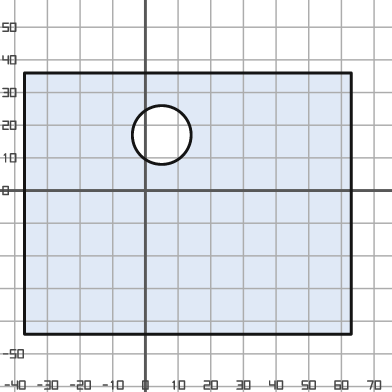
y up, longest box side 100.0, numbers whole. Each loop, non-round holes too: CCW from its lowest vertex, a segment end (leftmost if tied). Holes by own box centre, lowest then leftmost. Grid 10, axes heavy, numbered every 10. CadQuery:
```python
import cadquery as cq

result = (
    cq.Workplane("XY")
    .moveTo(-37.0, -44.0)
    .lineTo(63.0, -44.0)
    .lineTo(63.0, 36.0)
    .lineTo(-37.0, 36.0)
    .close()
    .moveTo(5.0, 17.0)
    .circle(9.0)
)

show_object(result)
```